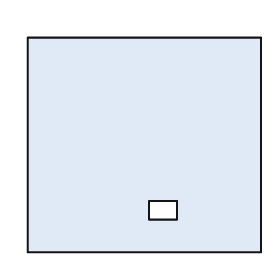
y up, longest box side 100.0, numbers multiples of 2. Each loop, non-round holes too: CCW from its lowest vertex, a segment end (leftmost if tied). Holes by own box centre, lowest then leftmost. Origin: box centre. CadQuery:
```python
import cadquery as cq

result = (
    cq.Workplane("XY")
    .moveTo(-50.0, -46.0)
    .lineTo(50.0, -46.0)
    .lineTo(50.0, 46.0)
    .lineTo(-50.0, 46.0)
    .close()
    .moveTo(2.0, -32.0)
    .lineTo(14.0, -32.0)
    .lineTo(14.0, -24.0)
    .lineTo(2.0, -24.0)
    .close()
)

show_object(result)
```